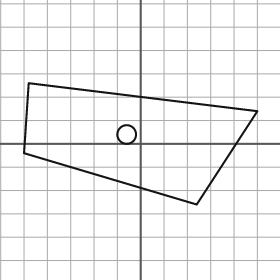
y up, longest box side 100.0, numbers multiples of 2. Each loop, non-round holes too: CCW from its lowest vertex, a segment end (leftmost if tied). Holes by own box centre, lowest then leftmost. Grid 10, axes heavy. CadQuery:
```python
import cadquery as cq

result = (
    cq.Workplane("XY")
    .moveTo(24.0, -26.0)
    .lineTo(50.0, 14.0)
    .lineTo(-48.0, 26.0)
    .lineTo(-50.0, -4.0)
    .close()
    .moveTo(-6.0, 4.0)
    .circle(4.0)
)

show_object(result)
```